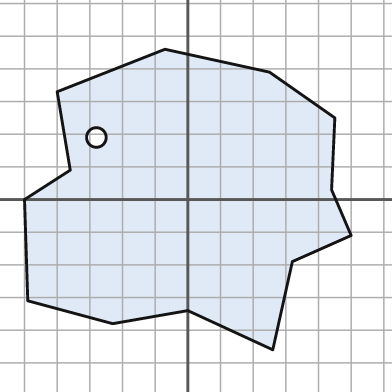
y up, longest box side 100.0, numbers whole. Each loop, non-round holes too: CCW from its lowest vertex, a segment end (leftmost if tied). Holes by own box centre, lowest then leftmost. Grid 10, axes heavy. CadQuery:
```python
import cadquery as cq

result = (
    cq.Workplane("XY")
    .moveTo(26.0, -46.0)
    .lineTo(32.0, -19.0)
    .lineTo(50.0, -11.0)
    .lineTo(44.0, 3.0)
    .lineTo(45.0, 25.0)
    .lineTo(25.0, 39.0)
    .lineTo(-7.0, 46.0)
    .lineTo(-40.0, 33.0)
    .lineTo(-36.0, 9.0)
    .lineTo(-50.0, 0.0)
    .lineTo(-49.0, -31.0)
    .lineTo(-23.0, -38.0)
    .lineTo(0.0, -34.0)
    .close()
    .moveTo(-28.0, 19.0)
    .circle(3.0)
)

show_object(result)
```